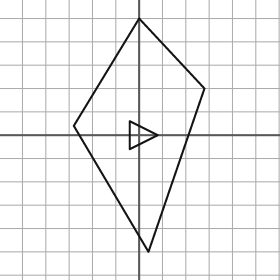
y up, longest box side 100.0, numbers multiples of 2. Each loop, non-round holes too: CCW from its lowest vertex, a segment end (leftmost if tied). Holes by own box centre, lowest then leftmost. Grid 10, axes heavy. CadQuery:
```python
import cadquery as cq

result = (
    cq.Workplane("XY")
    .moveTo(4.0, -50.0)
    .lineTo(28.0, 20.0)
    .lineTo(0.0, 50.0)
    .lineTo(-28.0, 4.0)
    .close()
    .moveTo(-4.0, -6.0)
    .lineTo(8.0, 0.0)
    .lineTo(-4.0, 6.0)
    .close()
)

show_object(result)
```